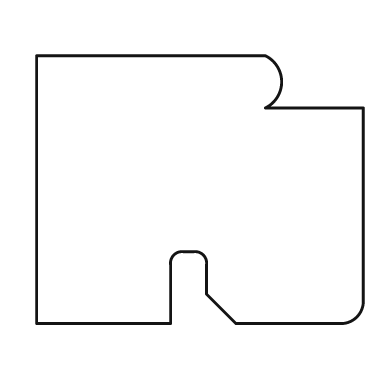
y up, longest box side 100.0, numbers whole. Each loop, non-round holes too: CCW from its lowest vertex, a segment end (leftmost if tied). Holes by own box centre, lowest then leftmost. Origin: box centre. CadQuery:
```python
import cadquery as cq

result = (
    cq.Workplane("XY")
    .moveTo(-50.0, -41.0)
    .lineTo(-9.0, -41.0)
    .lineTo(-9.0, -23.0)
    .threePointArc((-8.0, -20.0), (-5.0, -19.0))
    .lineTo(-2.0, -19.0)
    .threePointArc((1.0, -20.0), (2.0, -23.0))
    .lineTo(2.0, -32.0)
    .lineTo(11.0, -41.0)
    .lineTo(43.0, -41.0)
    .threePointArc((48.0, -39.0), (50.0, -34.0))
    .lineTo(50.0, 25.0)
    .lineTo(20.0, 25.0)
    .threePointArc((25.0, 33.0), (20.0, 41.0))
    .lineTo(-50.0, 41.0)
    .close()
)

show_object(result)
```